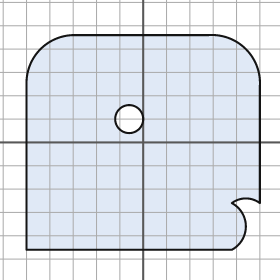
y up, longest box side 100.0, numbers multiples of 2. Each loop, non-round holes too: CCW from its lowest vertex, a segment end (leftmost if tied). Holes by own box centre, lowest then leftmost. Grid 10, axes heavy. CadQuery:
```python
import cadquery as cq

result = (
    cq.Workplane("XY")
    .moveTo(-50.0, -46.0)
    .lineTo(38.0, -46.0)
    .threePointArc((44.0, -36.0), (38.0, -26.0))
    .threePointArc((44.0, -24.0), (50.0, -26.0))
    .lineTo(50.0, 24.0)
    .threePointArc((44.0, 40.0), (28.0, 46.0))
    .lineTo(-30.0, 46.0)
    .threePointArc((-44.0, 40.0), (-50.0, 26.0))
    .close()
    .moveTo(-6.0, 10.0)
    .circle(6.0)
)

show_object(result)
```